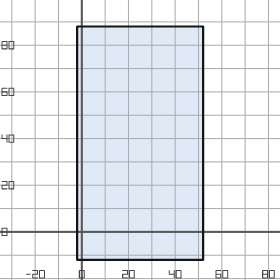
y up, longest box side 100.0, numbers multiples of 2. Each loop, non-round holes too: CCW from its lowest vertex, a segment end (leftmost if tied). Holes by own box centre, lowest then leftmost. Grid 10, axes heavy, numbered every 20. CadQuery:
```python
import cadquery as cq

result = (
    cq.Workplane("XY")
    .moveTo(-2.0, -12.0)
    .lineTo(52.0, -12.0)
    .lineTo(52.0, 88.0)
    .lineTo(-2.0, 88.0)
    .close()
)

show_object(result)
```